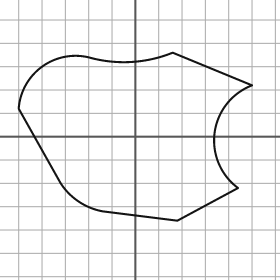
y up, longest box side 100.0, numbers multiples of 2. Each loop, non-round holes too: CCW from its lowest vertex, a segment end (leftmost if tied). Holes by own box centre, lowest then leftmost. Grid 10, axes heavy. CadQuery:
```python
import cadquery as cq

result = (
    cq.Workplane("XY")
    .moveTo(18.0, -36.0)
    .lineTo(44.0, -22.0)
    .threePointArc((34.0, 2.0), (50.0, 22.0))
    .lineTo(16.0, 36.0)
    .threePointArc((-2.0, 32.0), (-20.0, 34.0))
    .threePointArc((-40.0, 30.0), (-50.0, 12.0))
    .lineTo(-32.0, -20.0)
    .threePointArc((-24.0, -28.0), (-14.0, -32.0))
    .close()
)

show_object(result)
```